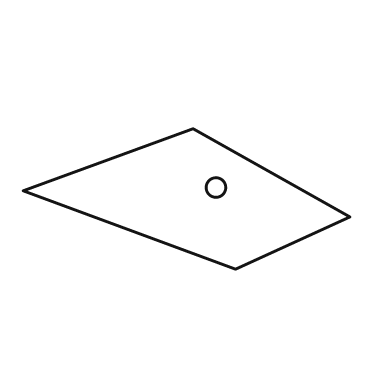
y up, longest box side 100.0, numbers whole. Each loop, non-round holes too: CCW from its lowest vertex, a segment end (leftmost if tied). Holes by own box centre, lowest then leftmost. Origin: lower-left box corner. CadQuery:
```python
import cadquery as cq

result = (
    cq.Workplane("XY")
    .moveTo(65.0, 0.0)
    .lineTo(100.0, 16.0)
    .lineTo(52.0, 43.0)
    .lineTo(0.0, 24.0)
    .close()
    .moveTo(59.0, 25.0)
    .circle(3.0)
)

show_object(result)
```